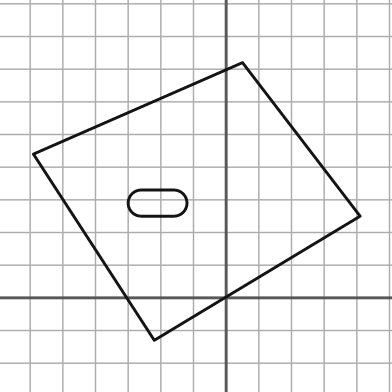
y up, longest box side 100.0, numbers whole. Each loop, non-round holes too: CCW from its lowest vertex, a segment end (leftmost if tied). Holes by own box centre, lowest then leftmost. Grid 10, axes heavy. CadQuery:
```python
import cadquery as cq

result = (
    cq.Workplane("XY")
    .moveTo(-22.0, -13.0)
    .lineTo(41.0, 25.0)
    .lineTo(5.0, 72.0)
    .lineTo(-59.0, 44.0)
    .close()
    .moveTo(-26.0, 25.0)
    .lineTo(-16.0, 25.0)
    .threePointArc((-12.0, 29.0), (-16.0, 33.0))
    .lineTo(-26.0, 33.0)
    .threePointArc((-30.0, 29.0), (-26.0, 25.0))
    .close()
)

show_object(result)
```